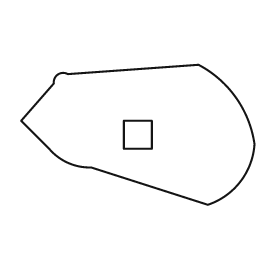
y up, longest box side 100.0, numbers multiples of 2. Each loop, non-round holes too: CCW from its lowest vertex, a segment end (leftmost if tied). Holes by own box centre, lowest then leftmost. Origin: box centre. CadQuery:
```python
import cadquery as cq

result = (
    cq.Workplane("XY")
    .moveTo(30.0, -30.0)
    .threePointArc((44.0, -20.0), (50.0, -4.0))
    .threePointArc((42.0, 16.0), (26.0, 30.0))
    .lineTo(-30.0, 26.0)
    .threePointArc((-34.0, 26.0), (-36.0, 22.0))
    .lineTo(-50.0, 6.0)
    .lineTo(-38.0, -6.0)
    .threePointArc((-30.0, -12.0), (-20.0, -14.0))
    .close()
    .moveTo(-6.0, -6.0)
    .lineTo(6.0, -6.0)
    .lineTo(6.0, 6.0)
    .lineTo(-6.0, 6.0)
    .close()
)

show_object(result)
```